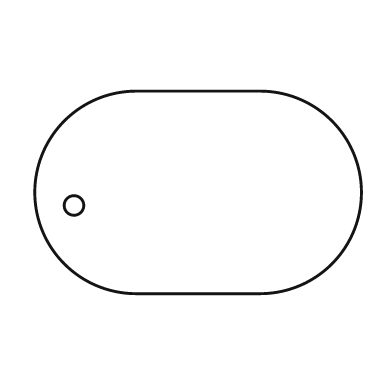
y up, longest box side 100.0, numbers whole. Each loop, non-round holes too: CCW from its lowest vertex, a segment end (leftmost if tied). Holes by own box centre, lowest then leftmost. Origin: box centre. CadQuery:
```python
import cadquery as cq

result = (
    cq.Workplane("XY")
    .moveTo(-19.0, -31.0)
    .lineTo(19.0, -31.0)
    .threePointArc((50.0, 0.0), (19.0, 31.0))
    .lineTo(-19.0, 31.0)
    .threePointArc((-50.0, 0.0), (-19.0, -31.0))
    .close()
    .moveTo(-38.0, -4.0)
    .circle(3.0)
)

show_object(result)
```